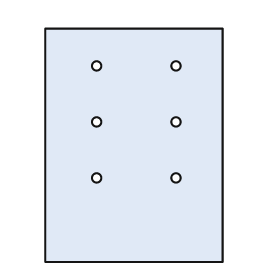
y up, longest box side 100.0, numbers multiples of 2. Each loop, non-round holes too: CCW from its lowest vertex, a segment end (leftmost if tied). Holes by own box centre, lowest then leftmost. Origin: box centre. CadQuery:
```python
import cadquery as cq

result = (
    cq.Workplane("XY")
    .moveTo(-38.0, -50.0)
    .lineTo(38.0, -50.0)
    .lineTo(38.0, 50.0)
    .lineTo(-38.0, 50.0)
    .close()
    .moveTo(-16.0, -14.0)
    .circle(2.0)
    .moveTo(18.0, -14.0)
    .circle(2.0)
    .moveTo(-16.0, 10.0)
    .circle(2.0)
    .moveTo(18.0, 10.0)
    .circle(2.0)
    .moveTo(-16.0, 34.0)
    .circle(2.0)
    .moveTo(18.0, 34.0)
    .circle(2.0)
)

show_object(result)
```